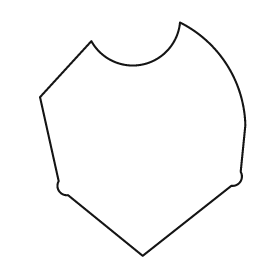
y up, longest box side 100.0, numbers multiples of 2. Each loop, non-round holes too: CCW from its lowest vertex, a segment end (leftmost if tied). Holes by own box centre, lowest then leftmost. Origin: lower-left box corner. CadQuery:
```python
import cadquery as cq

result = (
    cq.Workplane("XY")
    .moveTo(44.0, 0.0)
    .lineTo(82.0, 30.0)
    .threePointArc((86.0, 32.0), (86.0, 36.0))
    .lineTo(88.0, 56.0)
    .threePointArc((80.0, 82.0), (60.0, 100.0))
    .threePointArc((44.0, 82.0), (22.0, 92.0))
    .lineTo(0.0, 68.0)
    .lineTo(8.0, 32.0)
    .threePointArc((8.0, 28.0), (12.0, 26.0))
    .close()
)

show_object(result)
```